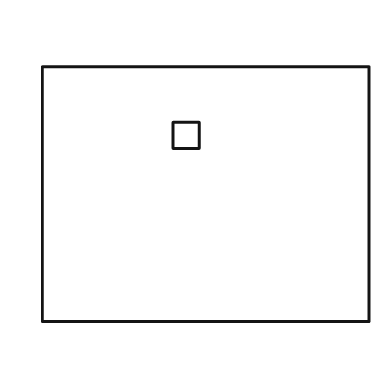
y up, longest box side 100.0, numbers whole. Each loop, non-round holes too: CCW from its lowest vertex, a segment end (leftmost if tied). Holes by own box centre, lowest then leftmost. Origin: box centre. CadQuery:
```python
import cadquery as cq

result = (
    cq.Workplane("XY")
    .moveTo(-50.0, -39.0)
    .lineTo(50.0, -39.0)
    .lineTo(50.0, 39.0)
    .lineTo(-50.0, 39.0)
    .close()
    .moveTo(-10.0, 14.0)
    .lineTo(-2.0, 14.0)
    .lineTo(-2.0, 22.0)
    .lineTo(-10.0, 22.0)
    .close()
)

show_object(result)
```